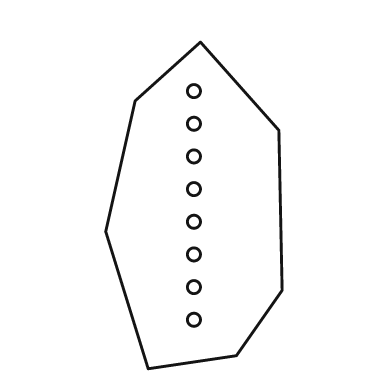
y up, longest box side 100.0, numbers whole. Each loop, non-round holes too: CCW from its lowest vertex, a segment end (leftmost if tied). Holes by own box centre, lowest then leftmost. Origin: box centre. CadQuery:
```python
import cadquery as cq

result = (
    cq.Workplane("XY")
    .moveTo(-14.0, -50.0)
    .lineTo(13.0, -46.0)
    .lineTo(27.0, -26.0)
    .lineTo(26.0, 23.0)
    .lineTo(2.0, 50.0)
    .lineTo(-18.0, 32.0)
    .lineTo(-27.0, -8.0)
    .close()
    .moveTo(0.0, -35.0)
    .circle(2.0)
    .moveTo(0.0, -25.0)
    .circle(2.0)
    .moveTo(0.0, -15.0)
    .circle(2.0)
    .moveTo(0.0, -5.0)
    .circle(2.0)
    .moveTo(0.0, 5.0)
    .circle(2.0)
    .moveTo(0.0, 15.0)
    .circle(2.0)
    .moveTo(0.0, 25.0)
    .circle(2.0)
    .moveTo(0.0, 35.0)
    .circle(2.0)
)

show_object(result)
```